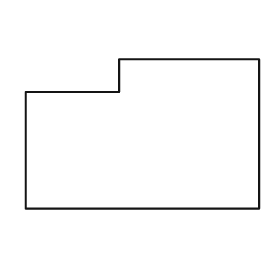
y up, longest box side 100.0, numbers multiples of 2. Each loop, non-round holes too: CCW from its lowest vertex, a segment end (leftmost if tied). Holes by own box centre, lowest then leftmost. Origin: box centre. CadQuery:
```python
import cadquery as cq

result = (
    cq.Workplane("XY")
    .moveTo(-50.0, -32.0)
    .lineTo(50.0, -32.0)
    .lineTo(50.0, 32.0)
    .lineTo(-10.0, 32.0)
    .lineTo(-10.0, 18.0)
    .lineTo(-50.0, 18.0)
    .close()
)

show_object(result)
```